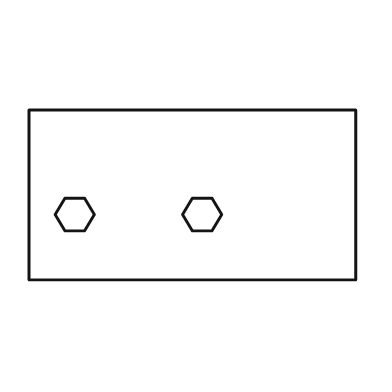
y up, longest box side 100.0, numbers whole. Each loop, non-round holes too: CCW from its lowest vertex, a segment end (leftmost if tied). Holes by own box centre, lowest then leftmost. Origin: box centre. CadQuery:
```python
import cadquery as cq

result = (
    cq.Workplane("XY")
    .moveTo(-50.0, -26.0)
    .lineTo(50.0, -26.0)
    .lineTo(50.0, 26.0)
    .lineTo(-50.0, 26.0)
    .close()
    .moveTo(-39.0, -11.0)
    .lineTo(-33.0, -11.0)
    .lineTo(-30.0, -6.0)
    .lineTo(-33.0, -1.0)
    .lineTo(-39.0, -1.0)
    .lineTo(-42.0, -6.0)
    .close()
    .moveTo(0.0, -11.0)
    .lineTo(6.0, -11.0)
    .lineTo(9.0, -6.0)
    .lineTo(6.0, -1.0)
    .lineTo(0.0, -1.0)
    .lineTo(-3.0, -6.0)
    .close()
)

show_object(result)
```